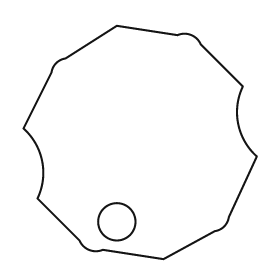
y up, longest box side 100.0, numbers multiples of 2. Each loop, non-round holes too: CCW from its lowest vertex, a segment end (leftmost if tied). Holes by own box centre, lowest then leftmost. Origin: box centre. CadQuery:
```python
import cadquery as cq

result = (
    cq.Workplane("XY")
    .moveTo(10.0, -50.0)
    .lineTo(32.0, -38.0)
    .threePointArc((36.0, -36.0), (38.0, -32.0))
    .lineTo(50.0, -6.0)
    .threePointArc((42.0, 8.0), (44.0, 24.0))
    .lineTo(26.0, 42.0)
    .threePointArc((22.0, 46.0), (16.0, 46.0))
    .lineTo(-10.0, 50.0)
    .lineTo(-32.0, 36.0)
    .threePointArc((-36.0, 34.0), (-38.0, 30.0))
    .lineTo(-50.0, 6.0)
    .threePointArc((-42.0, -8.0), (-44.0, -24.0))
    .lineTo(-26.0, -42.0)
    .threePointArc((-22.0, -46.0), (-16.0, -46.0))
    .close()
    .moveTo(-10.0, -34.0)
    .circle(8.0)
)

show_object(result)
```